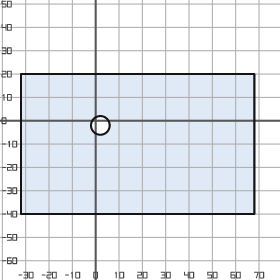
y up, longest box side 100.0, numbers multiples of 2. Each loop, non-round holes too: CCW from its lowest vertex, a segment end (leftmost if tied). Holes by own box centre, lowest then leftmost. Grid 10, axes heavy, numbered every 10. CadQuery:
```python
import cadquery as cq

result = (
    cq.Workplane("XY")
    .moveTo(-32.0, -40.0)
    .lineTo(68.0, -40.0)
    .lineTo(68.0, 20.0)
    .lineTo(-32.0, 20.0)
    .close()
    .moveTo(2.0, -2.0)
    .circle(4.0)
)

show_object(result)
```